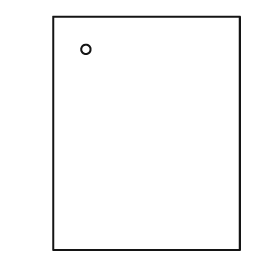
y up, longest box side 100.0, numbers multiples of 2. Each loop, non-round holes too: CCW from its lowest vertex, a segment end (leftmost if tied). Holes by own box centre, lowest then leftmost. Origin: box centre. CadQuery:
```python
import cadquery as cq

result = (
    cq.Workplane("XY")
    .moveTo(-40.0, -50.0)
    .lineTo(40.0, -50.0)
    .lineTo(40.0, 50.0)
    .lineTo(-40.0, 50.0)
    .close()
    .moveTo(-26.0, 36.0)
    .circle(2.0)
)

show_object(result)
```